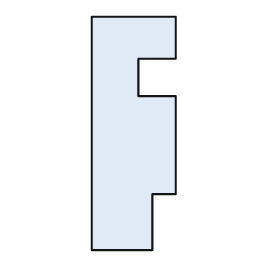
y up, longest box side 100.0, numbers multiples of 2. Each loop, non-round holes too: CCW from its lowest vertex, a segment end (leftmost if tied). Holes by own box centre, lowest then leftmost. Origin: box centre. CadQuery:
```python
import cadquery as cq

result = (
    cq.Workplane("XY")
    .moveTo(-18.0, -50.0)
    .lineTo(8.0, -50.0)
    .lineTo(8.0, -26.0)
    .lineTo(18.0, -26.0)
    .lineTo(18.0, 16.0)
    .lineTo(2.0, 16.0)
    .lineTo(2.0, 32.0)
    .lineTo(18.0, 32.0)
    .lineTo(18.0, 50.0)
    .lineTo(-18.0, 50.0)
    .close()
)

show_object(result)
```